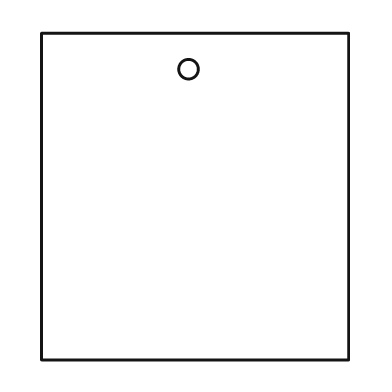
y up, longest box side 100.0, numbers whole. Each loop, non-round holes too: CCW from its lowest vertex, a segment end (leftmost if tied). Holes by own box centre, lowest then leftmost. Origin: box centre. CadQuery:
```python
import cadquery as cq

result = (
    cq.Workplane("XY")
    .moveTo(-47.0, -50.0)
    .lineTo(47.0, -50.0)
    .lineTo(47.0, 50.0)
    .lineTo(-47.0, 50.0)
    .close()
    .moveTo(-2.0, 39.0)
    .circle(3.0)
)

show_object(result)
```